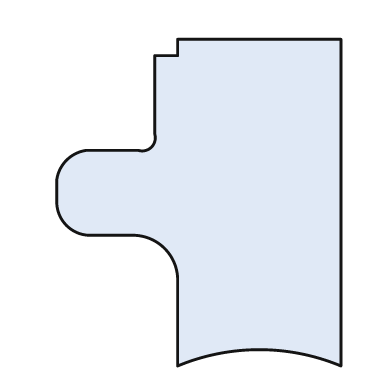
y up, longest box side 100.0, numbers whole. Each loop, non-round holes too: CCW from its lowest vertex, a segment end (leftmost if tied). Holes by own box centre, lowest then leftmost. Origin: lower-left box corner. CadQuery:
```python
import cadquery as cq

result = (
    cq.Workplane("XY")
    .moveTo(37.0, 0.0)
    .threePointArc((62.0, 5.0), (87.0, 0.0))
    .lineTo(87.0, 100.0)
    .lineTo(37.0, 100.0)
    .lineTo(37.0, 95.0)
    .lineTo(30.0, 95.0)
    .lineTo(30.0, 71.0)
    .threePointArc((29.0, 67.0), (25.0, 66.0))
    .lineTo(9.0, 66.0)
    .threePointArc((3.0, 63.0), (0.0, 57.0))
    .lineTo(0.0, 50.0)
    .threePointArc((3.0, 43.0), (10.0, 40.0))
    .lineTo(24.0, 40.0)
    .threePointArc((33.0, 36.0), (37.0, 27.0))
    .close()
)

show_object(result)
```